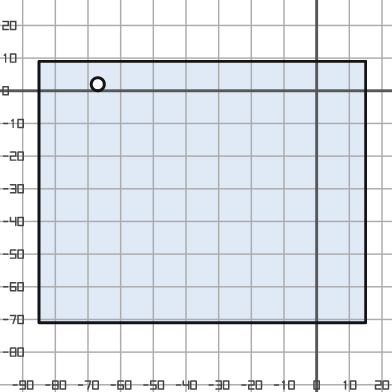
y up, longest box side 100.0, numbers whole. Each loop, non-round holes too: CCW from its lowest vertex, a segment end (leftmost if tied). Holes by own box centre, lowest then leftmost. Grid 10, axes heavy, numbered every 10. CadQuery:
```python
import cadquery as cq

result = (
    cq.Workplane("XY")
    .moveTo(-85.0, -71.0)
    .lineTo(15.0, -71.0)
    .lineTo(15.0, 9.0)
    .lineTo(-85.0, 9.0)
    .close()
    .moveTo(-67.0, 2.0)
    .circle(2.0)
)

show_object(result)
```